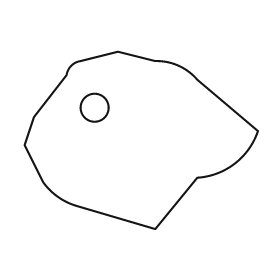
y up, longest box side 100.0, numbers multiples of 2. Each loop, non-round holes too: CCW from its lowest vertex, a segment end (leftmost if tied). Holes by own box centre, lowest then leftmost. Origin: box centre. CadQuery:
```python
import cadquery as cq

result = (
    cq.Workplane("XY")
    .moveTo(6.0, -38.0)
    .lineTo(24.0, -16.0)
    .threePointArc((40.0, -10.0), (50.0, 4.0))
    .lineTo(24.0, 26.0)
    .threePointArc((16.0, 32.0), (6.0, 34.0))
    .lineTo(-10.0, 38.0)
    .lineTo(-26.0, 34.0)
    .threePointArc((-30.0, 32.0), (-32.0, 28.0))
    .lineTo(-46.0, 10.0)
    .lineTo(-50.0, -2.0)
    .lineTo(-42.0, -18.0)
    .threePointArc((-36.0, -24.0), (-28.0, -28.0))
    .close()
    .moveTo(-20.0, 14.0)
    .circle(6.0)
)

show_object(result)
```